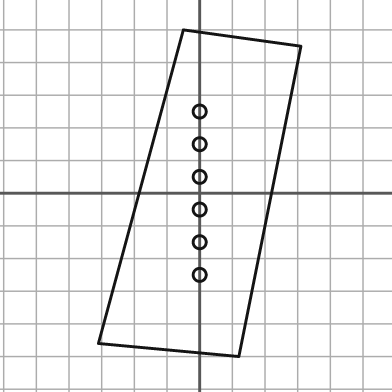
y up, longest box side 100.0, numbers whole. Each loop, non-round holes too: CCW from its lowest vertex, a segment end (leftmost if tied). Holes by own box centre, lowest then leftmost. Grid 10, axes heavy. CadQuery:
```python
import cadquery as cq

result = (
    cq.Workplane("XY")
    .moveTo(12.0, -50.0)
    .lineTo(31.0, 45.0)
    .lineTo(-5.0, 50.0)
    .lineTo(-31.0, -46.0)
    .close()
    .moveTo(0.0, -25.0)
    .circle(2.0)
    .moveTo(0.0, -15.0)
    .circle(2.0)
    .moveTo(0.0, -5.0)
    .circle(2.0)
    .moveTo(0.0, 5.0)
    .circle(2.0)
    .moveTo(0.0, 15.0)
    .circle(2.0)
    .moveTo(0.0, 25.0)
    .circle(2.0)
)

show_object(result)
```